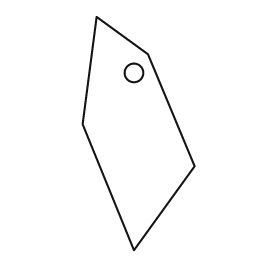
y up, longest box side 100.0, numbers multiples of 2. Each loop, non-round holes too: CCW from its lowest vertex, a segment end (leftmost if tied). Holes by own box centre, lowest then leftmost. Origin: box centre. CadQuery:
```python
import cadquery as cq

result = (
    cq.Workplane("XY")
    .moveTo(-2.0, -50.0)
    .lineTo(24.0, -14.0)
    .lineTo(4.0, 34.0)
    .lineTo(-18.0, 50.0)
    .lineTo(-24.0, 4.0)
    .close()
    .moveTo(-2.0, 26.0)
    .circle(4.0)
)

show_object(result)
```